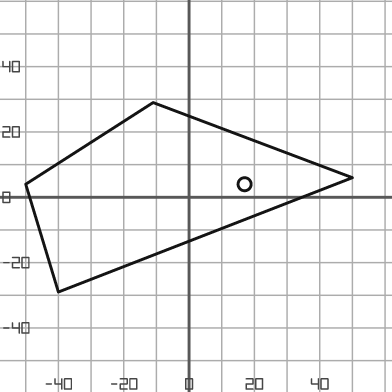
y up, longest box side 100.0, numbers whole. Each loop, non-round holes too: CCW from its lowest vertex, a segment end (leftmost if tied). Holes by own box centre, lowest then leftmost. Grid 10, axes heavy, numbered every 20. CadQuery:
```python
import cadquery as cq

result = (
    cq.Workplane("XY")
    .moveTo(-40.0, -29.0)
    .lineTo(50.0, 6.0)
    .lineTo(-11.0, 29.0)
    .lineTo(-50.0, 4.0)
    .close()
    .moveTo(17.0, 4.0)
    .circle(2.0)
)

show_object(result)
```